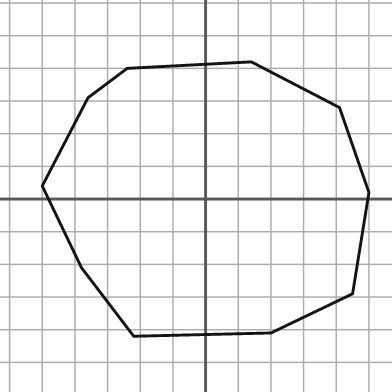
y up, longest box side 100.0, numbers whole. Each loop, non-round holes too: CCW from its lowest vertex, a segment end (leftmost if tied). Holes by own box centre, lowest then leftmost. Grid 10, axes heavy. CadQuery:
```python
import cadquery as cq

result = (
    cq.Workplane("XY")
    .moveTo(-22.0, -42.0)
    .lineTo(20.0, -41.0)
    .lineTo(45.0, -29.0)
    .lineTo(50.0, 2.0)
    .lineTo(41.0, 28.0)
    .lineTo(14.0, 42.0)
    .lineTo(-24.0, 40.0)
    .lineTo(-36.0, 31.0)
    .lineTo(-50.0, 4.0)
    .lineTo(-38.0, -21.0)
    .close()
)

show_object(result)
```